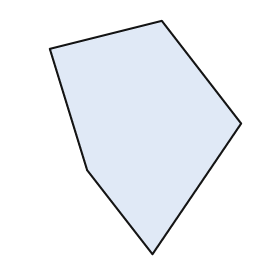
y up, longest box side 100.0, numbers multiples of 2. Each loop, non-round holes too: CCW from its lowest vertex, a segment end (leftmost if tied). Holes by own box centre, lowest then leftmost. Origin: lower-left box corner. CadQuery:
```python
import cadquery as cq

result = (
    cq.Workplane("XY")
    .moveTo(44.0, 0.0)
    .lineTo(82.0, 56.0)
    .lineTo(48.0, 100.0)
    .lineTo(0.0, 88.0)
    .lineTo(16.0, 36.0)
    .close()
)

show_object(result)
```